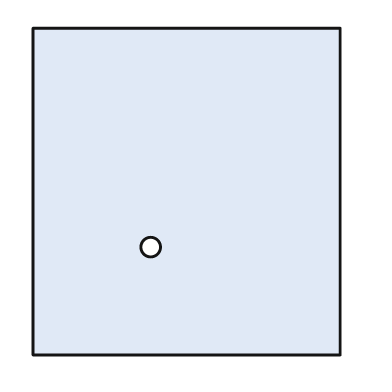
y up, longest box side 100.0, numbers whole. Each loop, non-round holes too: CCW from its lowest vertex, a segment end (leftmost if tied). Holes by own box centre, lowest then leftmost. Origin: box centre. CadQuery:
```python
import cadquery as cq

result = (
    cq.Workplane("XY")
    .moveTo(-47.0, -50.0)
    .lineTo(47.0, -50.0)
    .lineTo(47.0, 50.0)
    .lineTo(-47.0, 50.0)
    .close()
    .moveTo(-11.0, -17.0)
    .circle(3.0)
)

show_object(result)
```